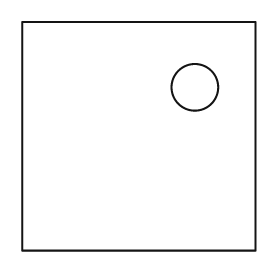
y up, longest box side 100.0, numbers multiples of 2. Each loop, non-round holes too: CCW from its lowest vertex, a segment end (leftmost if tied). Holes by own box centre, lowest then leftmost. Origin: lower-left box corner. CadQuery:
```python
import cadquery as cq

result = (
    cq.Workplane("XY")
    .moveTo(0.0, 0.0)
    .lineTo(100.0, 0.0)
    .lineTo(100.0, 98.0)
    .lineTo(0.0, 98.0)
    .close()
    .moveTo(74.0, 70.0)
    .circle(10.0)
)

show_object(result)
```